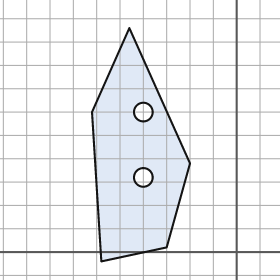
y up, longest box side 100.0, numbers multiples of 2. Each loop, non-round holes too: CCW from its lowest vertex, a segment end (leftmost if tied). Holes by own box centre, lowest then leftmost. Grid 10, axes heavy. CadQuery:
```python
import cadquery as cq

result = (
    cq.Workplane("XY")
    .moveTo(-58.0, -4.0)
    .lineTo(-30.0, 2.0)
    .lineTo(-20.0, 38.0)
    .lineTo(-46.0, 96.0)
    .lineTo(-62.0, 60.0)
    .close()
    .moveTo(-40.0, 32.0)
    .circle(4.0)
    .moveTo(-40.0, 60.0)
    .circle(4.0)
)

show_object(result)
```